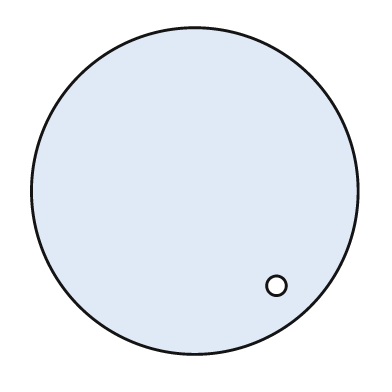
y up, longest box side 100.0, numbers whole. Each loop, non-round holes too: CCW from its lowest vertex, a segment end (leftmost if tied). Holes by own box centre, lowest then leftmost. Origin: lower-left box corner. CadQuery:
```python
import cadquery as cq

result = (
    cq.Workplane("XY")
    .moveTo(50.0, 50.0)
    .circle(50.0)
    .moveTo(75.0, 21.0)
    .circle(3.0)
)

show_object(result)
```